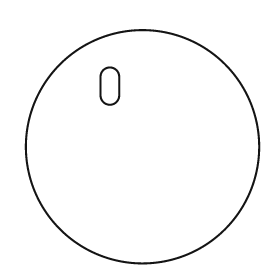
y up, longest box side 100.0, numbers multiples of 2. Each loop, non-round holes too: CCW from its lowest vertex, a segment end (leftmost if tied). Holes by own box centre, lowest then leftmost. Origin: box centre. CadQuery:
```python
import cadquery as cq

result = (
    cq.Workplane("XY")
    .moveTo(0.0, 0.0)
    .circle(50.0)
    .moveTo(-18.0, 22.0)
    .threePointArc((-14.0, 18.0), (-10.0, 22.0))
    .lineTo(-10.0, 30.0)
    .threePointArc((-14.0, 34.0), (-18.0, 30.0))
    .close()
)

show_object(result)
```